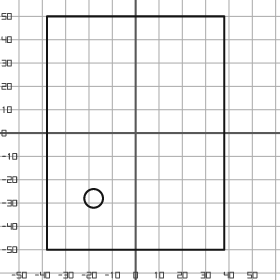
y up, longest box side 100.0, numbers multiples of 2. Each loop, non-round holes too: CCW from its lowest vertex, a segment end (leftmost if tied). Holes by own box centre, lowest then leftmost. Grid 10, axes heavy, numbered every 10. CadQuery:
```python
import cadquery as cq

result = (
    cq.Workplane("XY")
    .moveTo(-38.0, -50.0)
    .lineTo(38.0, -50.0)
    .lineTo(38.0, 50.0)
    .lineTo(-38.0, 50.0)
    .close()
    .moveTo(-18.0, -28.0)
    .circle(4.0)
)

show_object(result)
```